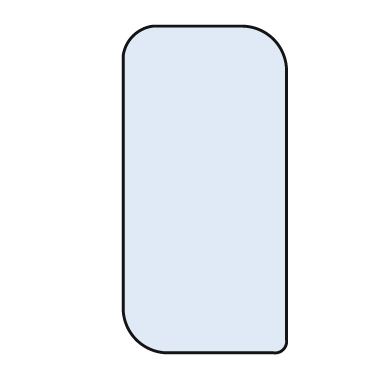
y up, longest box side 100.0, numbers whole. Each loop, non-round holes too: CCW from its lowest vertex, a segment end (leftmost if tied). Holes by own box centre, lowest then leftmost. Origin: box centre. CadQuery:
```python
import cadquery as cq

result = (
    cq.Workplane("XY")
    .moveTo(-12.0, -50.0)
    .lineTo(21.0, -50.0)
    .threePointArc((24.0, -49.0), (25.0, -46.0))
    .lineTo(25.0, 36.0)
    .threePointArc((21.0, 46.0), (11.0, 50.0))
    .lineTo(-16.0, 50.0)
    .threePointArc((-22.0, 47.0), (-25.0, 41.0))
    .lineTo(-25.0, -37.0)
    .threePointArc((-21.0, -46.0), (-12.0, -50.0))
    .close()
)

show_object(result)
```